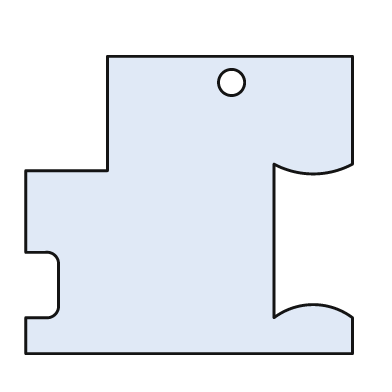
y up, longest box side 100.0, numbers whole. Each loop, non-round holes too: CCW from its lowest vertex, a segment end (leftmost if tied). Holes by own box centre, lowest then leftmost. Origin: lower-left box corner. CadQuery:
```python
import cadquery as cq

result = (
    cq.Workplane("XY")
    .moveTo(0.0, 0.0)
    .lineTo(100.0, 0.0)
    .lineTo(100.0, 11.0)
    .threePointArc((88.0, 15.0), (76.0, 11.0))
    .lineTo(76.0, 58.0)
    .threePointArc((88.0, 55.0), (100.0, 58.0))
    .lineTo(100.0, 91.0)
    .lineTo(25.0, 91.0)
    .lineTo(25.0, 56.0)
    .lineTo(0.0, 56.0)
    .lineTo(0.0, 31.0)
    .lineTo(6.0, 31.0)
    .threePointArc((9.0, 30.0), (10.0, 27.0))
    .lineTo(10.0, 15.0)
    .threePointArc((9.0, 12.0), (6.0, 11.0))
    .lineTo(0.0, 11.0)
    .close()
    .moveTo(63.0, 83.0)
    .circle(4.0)
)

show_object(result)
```